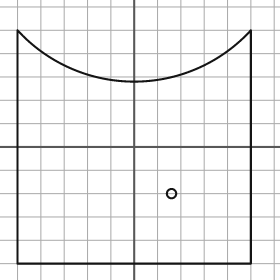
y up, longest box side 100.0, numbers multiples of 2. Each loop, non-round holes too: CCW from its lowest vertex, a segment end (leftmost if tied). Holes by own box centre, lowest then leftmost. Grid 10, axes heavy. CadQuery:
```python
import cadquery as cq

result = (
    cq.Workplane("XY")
    .moveTo(-50.0, -50.0)
    .lineTo(50.0, -50.0)
    .lineTo(50.0, 50.0)
    .threePointArc((0.0, 28.0), (-50.0, 50.0))
    .close()
    .moveTo(16.0, -20.0)
    .circle(2.0)
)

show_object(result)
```